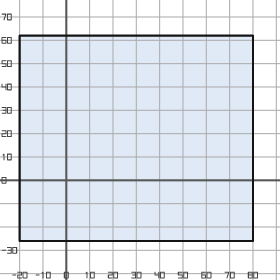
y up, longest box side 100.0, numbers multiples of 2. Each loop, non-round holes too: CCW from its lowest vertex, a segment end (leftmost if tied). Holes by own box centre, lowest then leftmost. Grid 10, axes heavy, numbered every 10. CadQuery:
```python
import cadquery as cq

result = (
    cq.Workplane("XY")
    .moveTo(-20.0, -26.0)
    .lineTo(80.0, -26.0)
    .lineTo(80.0, 62.0)
    .lineTo(-20.0, 62.0)
    .close()
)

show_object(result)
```